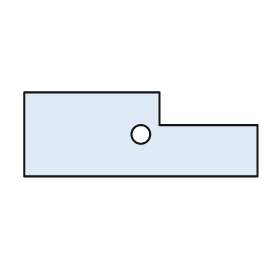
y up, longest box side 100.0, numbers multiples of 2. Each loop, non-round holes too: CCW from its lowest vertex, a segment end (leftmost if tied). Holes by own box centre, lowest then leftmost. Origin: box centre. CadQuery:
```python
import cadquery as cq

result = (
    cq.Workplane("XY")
    .moveTo(-50.0, -18.0)
    .lineTo(50.0, -18.0)
    .lineTo(50.0, 4.0)
    .lineTo(8.0, 4.0)
    .lineTo(8.0, 18.0)
    .lineTo(-50.0, 18.0)
    .close()
    .moveTo(0.0, 0.0)
    .circle(4.0)
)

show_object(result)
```